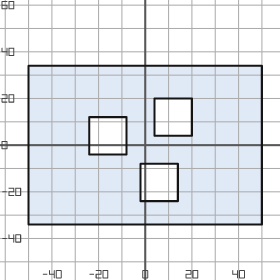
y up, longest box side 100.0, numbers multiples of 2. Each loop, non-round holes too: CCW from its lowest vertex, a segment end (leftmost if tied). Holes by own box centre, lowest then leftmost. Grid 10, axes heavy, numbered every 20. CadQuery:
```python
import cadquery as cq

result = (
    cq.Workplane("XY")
    .moveTo(-50.0, -34.0)
    .lineTo(50.0, -34.0)
    .lineTo(50.0, 34.0)
    .lineTo(-50.0, 34.0)
    .close()
    .moveTo(-2.0, -24.0)
    .lineTo(14.0, -24.0)
    .lineTo(14.0, -8.0)
    .lineTo(-2.0, -8.0)
    .close()
    .moveTo(-24.0, -4.0)
    .lineTo(-8.0, -4.0)
    .lineTo(-8.0, 12.0)
    .lineTo(-24.0, 12.0)
    .close()
    .moveTo(4.0, 4.0)
    .lineTo(20.0, 4.0)
    .lineTo(20.0, 20.0)
    .lineTo(4.0, 20.0)
    .close()
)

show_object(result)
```